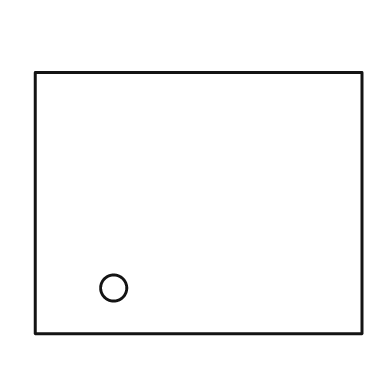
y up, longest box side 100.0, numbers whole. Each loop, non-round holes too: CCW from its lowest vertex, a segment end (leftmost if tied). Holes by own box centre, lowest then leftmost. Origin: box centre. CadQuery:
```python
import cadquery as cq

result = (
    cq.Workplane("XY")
    .moveTo(-50.0, -40.0)
    .lineTo(50.0, -40.0)
    .lineTo(50.0, 40.0)
    .lineTo(-50.0, 40.0)
    .close()
    .moveTo(-26.0, -26.0)
    .circle(4.0)
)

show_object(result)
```